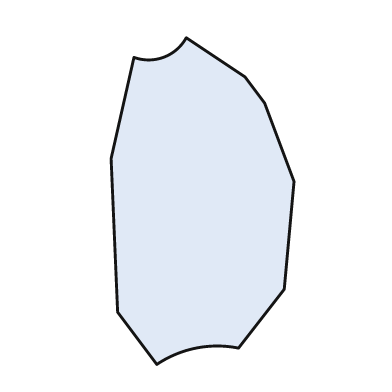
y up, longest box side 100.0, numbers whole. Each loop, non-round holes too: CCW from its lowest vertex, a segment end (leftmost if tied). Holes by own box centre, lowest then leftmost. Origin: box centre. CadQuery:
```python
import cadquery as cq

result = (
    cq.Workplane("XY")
    .moveTo(-14.0, -50.0)
    .threePointArc((-2.0, -45.0), (11.0, -45.0))
    .lineTo(25.0, -27.0)
    .lineTo(28.0, 6.0)
    .lineTo(19.0, 30.0)
    .lineTo(13.0, 38.0)
    .lineTo(-5.0, 50.0)
    .threePointArc((-12.0, 44.0), (-21.0, 44.0))
    .lineTo(-28.0, 13.0)
    .lineTo(-26.0, -34.0)
    .close()
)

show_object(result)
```